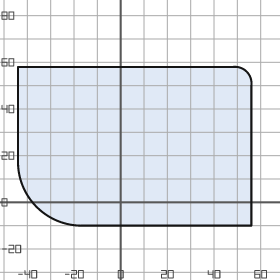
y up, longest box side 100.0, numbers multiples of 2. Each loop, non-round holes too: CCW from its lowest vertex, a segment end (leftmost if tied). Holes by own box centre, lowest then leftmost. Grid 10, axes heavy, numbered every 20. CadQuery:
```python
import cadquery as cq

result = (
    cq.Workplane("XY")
    .moveTo(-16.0, -10.0)
    .lineTo(56.0, -10.0)
    .lineTo(56.0, 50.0)
    .threePointArc((54.0, 56.0), (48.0, 58.0))
    .lineTo(-44.0, 58.0)
    .lineTo(-44.0, 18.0)
    .threePointArc((-36.0, -2.0), (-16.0, -10.0))
    .close()
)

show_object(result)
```